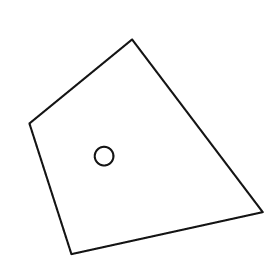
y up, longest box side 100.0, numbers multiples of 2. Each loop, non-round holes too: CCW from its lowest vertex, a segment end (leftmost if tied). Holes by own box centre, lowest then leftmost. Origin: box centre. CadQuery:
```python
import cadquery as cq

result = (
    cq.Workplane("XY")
    .moveTo(-32.0, -46.0)
    .lineTo(50.0, -28.0)
    .lineTo(-6.0, 46.0)
    .lineTo(-50.0, 10.0)
    .close()
    .moveTo(-18.0, -4.0)
    .circle(4.0)
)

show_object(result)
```